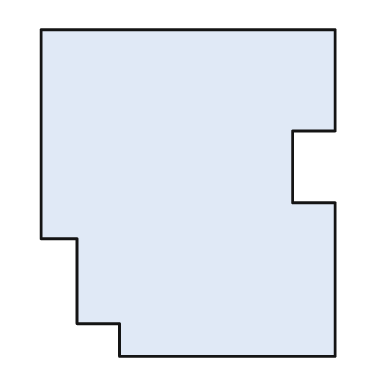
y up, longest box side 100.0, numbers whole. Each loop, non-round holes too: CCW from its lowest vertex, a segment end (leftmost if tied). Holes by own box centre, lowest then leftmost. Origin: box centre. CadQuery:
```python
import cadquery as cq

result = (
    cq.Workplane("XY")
    .moveTo(-21.0, -50.0)
    .lineTo(45.0, -50.0)
    .lineTo(45.0, -3.0)
    .lineTo(32.0, -3.0)
    .lineTo(32.0, 19.0)
    .lineTo(45.0, 19.0)
    .lineTo(45.0, 50.0)
    .lineTo(-45.0, 50.0)
    .lineTo(-45.0, -14.0)
    .lineTo(-34.0, -14.0)
    .lineTo(-34.0, -40.0)
    .lineTo(-21.0, -40.0)
    .close()
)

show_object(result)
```